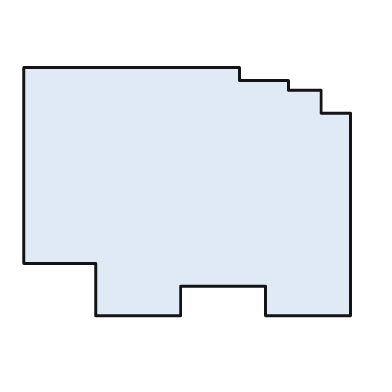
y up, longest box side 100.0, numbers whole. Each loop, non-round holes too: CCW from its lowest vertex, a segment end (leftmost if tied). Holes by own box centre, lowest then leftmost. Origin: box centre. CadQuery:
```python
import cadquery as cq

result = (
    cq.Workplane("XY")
    .moveTo(-28.0, -38.0)
    .lineTo(-2.0, -38.0)
    .lineTo(-2.0, -29.0)
    .lineTo(24.0, -29.0)
    .lineTo(24.0, -38.0)
    .lineTo(50.0, -38.0)
    .lineTo(50.0, 24.0)
    .lineTo(41.0, 24.0)
    .lineTo(41.0, 31.0)
    .lineTo(31.0, 31.0)
    .lineTo(31.0, 34.0)
    .lineTo(16.0, 34.0)
    .lineTo(16.0, 38.0)
    .lineTo(-50.0, 38.0)
    .lineTo(-50.0, -22.0)
    .lineTo(-28.0, -22.0)
    .close()
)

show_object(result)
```